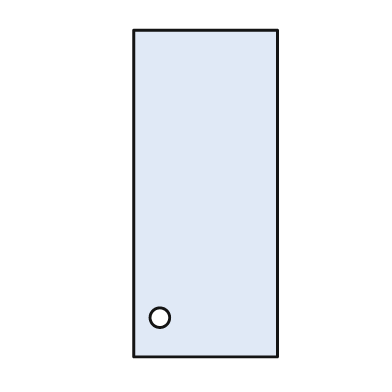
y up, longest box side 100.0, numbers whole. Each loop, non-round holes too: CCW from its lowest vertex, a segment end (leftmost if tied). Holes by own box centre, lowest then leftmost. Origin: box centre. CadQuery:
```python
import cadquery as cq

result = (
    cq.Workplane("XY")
    .moveTo(-22.0, -50.0)
    .lineTo(22.0, -50.0)
    .lineTo(22.0, 50.0)
    .lineTo(-22.0, 50.0)
    .close()
    .moveTo(-14.0, -38.0)
    .circle(3.0)
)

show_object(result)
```